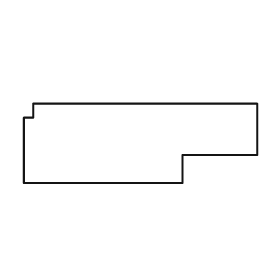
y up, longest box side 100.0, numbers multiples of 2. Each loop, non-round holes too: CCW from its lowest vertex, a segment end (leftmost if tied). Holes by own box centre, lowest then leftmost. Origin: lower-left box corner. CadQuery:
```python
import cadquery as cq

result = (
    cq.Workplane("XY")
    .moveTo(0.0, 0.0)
    .lineTo(68.0, 0.0)
    .lineTo(68.0, 12.0)
    .lineTo(100.0, 12.0)
    .lineTo(100.0, 34.0)
    .lineTo(4.0, 34.0)
    .lineTo(4.0, 28.0)
    .lineTo(0.0, 28.0)
    .close()
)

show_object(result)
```